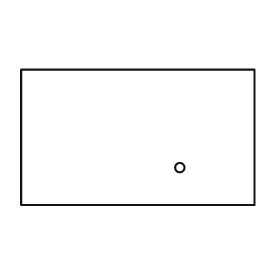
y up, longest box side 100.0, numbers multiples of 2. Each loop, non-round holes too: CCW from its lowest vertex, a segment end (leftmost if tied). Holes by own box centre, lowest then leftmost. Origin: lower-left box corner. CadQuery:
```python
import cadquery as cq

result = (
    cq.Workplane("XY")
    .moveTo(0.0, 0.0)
    .lineTo(100.0, 0.0)
    .lineTo(100.0, 58.0)
    .lineTo(0.0, 58.0)
    .close()
    .moveTo(68.0, 16.0)
    .circle(2.0)
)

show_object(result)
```